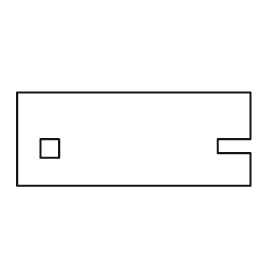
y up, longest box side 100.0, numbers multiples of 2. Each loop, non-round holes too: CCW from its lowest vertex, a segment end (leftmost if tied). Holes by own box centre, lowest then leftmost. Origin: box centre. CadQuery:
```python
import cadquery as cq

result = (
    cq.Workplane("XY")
    .moveTo(-50.0, -20.0)
    .lineTo(50.0, -20.0)
    .lineTo(50.0, -6.0)
    .lineTo(36.0, -6.0)
    .lineTo(36.0, 0.0)
    .lineTo(50.0, 0.0)
    .lineTo(50.0, 20.0)
    .lineTo(-50.0, 20.0)
    .close()
    .moveTo(-40.0, -8.0)
    .lineTo(-32.0, -8.0)
    .lineTo(-32.0, 0.0)
    .lineTo(-40.0, 0.0)
    .close()
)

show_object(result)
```